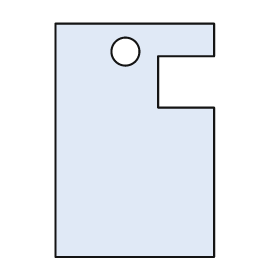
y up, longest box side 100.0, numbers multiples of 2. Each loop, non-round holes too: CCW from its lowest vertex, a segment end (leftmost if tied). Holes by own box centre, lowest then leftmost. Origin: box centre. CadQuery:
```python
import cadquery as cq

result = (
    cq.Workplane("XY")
    .moveTo(-34.0, -50.0)
    .lineTo(34.0, -50.0)
    .lineTo(34.0, 14.0)
    .lineTo(10.0, 14.0)
    .lineTo(10.0, 36.0)
    .lineTo(34.0, 36.0)
    .lineTo(34.0, 50.0)
    .lineTo(-34.0, 50.0)
    .close()
    .moveTo(-4.0, 38.0)
    .circle(6.0)
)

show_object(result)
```